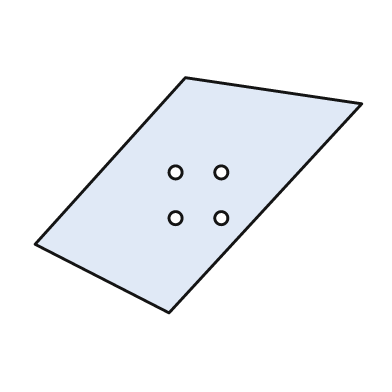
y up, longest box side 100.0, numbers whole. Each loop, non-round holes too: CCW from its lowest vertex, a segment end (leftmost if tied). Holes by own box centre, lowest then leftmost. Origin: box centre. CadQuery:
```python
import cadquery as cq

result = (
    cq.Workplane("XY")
    .moveTo(-9.0, -36.0)
    .lineTo(50.0, 28.0)
    .lineTo(-4.0, 36.0)
    .lineTo(-50.0, -15.0)
    .close()
    .moveTo(-7.0, -7.0)
    .circle(2.0)
    .moveTo(7.0, -7.0)
    .circle(2.0)
    .moveTo(-7.0, 7.0)
    .circle(2.0)
    .moveTo(7.0, 7.0)
    .circle(2.0)
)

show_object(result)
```